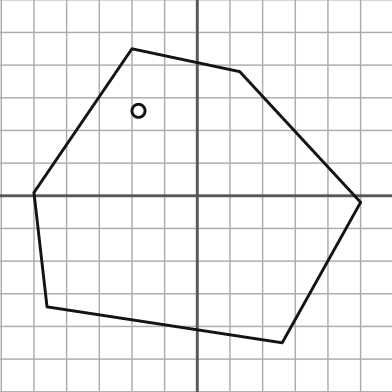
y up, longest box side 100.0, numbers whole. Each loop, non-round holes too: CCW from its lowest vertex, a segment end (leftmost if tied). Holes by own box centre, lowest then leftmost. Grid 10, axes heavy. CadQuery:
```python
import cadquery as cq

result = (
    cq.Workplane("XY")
    .moveTo(26.0, -45.0)
    .lineTo(50.0, -2.0)
    .lineTo(13.0, 38.0)
    .lineTo(-20.0, 45.0)
    .lineTo(-50.0, 1.0)
    .lineTo(-46.0, -34.0)
    .close()
    .moveTo(-18.0, 26.0)
    .circle(2.0)
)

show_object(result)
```